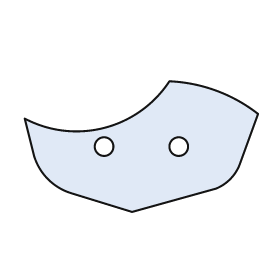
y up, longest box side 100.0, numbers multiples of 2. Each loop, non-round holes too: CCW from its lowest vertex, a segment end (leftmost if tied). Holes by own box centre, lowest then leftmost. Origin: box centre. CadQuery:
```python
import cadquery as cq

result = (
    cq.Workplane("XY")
    .moveTo(-4.0, -28.0)
    .lineTo(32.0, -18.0)
    .threePointArc((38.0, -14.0), (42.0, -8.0))
    .lineTo(50.0, 14.0)
    .threePointArc((32.0, 24.0), (12.0, 28.0))
    .threePointArc((-16.0, 8.0), (-50.0, 12.0))
    .lineTo(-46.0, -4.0)
    .threePointArc((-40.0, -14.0), (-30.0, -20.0))
    .close()
    .moveTo(-16.0, 0.0)
    .circle(4.0)
    .moveTo(16.0, 0.0)
    .circle(4.0)
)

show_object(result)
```